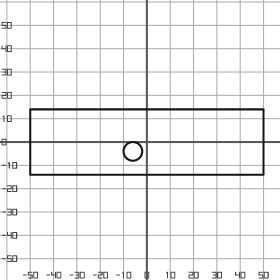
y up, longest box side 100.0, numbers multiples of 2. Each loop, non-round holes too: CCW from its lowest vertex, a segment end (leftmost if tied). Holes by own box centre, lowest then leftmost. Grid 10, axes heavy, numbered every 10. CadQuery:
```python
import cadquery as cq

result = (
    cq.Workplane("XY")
    .moveTo(-50.0, -14.0)
    .lineTo(50.0, -14.0)
    .lineTo(50.0, 14.0)
    .lineTo(-50.0, 14.0)
    .close()
    .moveTo(-6.0, -4.0)
    .circle(4.0)
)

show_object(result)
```